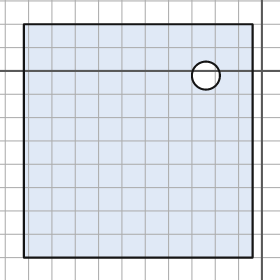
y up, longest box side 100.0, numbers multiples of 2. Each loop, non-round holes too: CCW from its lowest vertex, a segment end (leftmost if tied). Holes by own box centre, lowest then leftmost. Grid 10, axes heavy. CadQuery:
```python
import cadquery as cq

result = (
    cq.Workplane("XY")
    .moveTo(-102.0, -80.0)
    .lineTo(-4.0, -80.0)
    .lineTo(-4.0, 20.0)
    .lineTo(-102.0, 20.0)
    .close()
    .moveTo(-24.0, -2.0)
    .circle(6.0)
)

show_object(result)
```